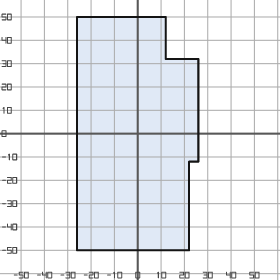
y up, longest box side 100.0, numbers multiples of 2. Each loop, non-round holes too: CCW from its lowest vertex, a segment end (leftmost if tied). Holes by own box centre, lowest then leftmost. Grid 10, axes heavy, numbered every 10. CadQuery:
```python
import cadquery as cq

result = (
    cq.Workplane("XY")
    .moveTo(-26.0, -50.0)
    .lineTo(22.0, -50.0)
    .lineTo(22.0, -12.0)
    .lineTo(26.0, -12.0)
    .lineTo(26.0, 32.0)
    .lineTo(12.0, 32.0)
    .lineTo(12.0, 50.0)
    .lineTo(-26.0, 50.0)
    .close()
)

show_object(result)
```